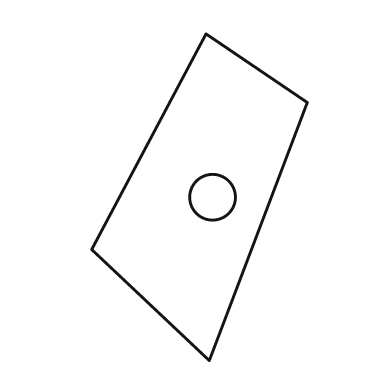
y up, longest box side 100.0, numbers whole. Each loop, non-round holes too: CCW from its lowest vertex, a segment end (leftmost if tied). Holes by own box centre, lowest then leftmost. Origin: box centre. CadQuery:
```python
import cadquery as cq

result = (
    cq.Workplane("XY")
    .moveTo(3.0, -50.0)
    .lineTo(33.0, 29.0)
    .lineTo(2.0, 50.0)
    .lineTo(-33.0, -16.0)
    .close()
    .moveTo(4.0, 0.0)
    .circle(7.0)
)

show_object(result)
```